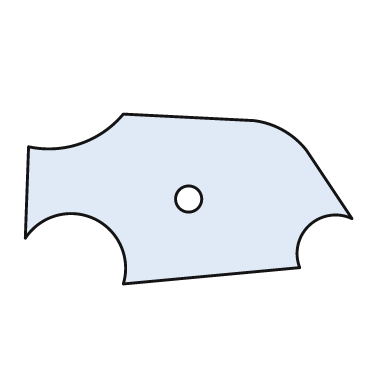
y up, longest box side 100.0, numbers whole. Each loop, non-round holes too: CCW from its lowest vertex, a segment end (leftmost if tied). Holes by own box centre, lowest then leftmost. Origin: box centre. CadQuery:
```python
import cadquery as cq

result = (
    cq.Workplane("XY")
    .moveTo(-20.0, -26.0)
    .lineTo(34.0, -21.0)
    .threePointArc((37.0, -8.0), (50.0, -6.0))
    .lineTo(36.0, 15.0)
    .threePointArc((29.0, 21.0), (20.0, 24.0))
    .lineTo(-20.0, 26.0)
    .threePointArc((-33.0, 17.0), (-49.0, 16.0))
    .lineTo(-50.0, -12.0)
    .threePointArc((-29.0, -6.0), (-20.0, -26.0))
    .close()
    .moveTo(0.0, 0.0)
    .circle(4.0)
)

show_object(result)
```